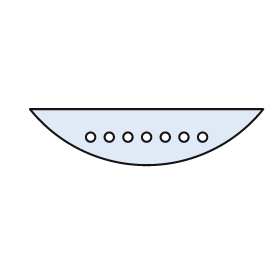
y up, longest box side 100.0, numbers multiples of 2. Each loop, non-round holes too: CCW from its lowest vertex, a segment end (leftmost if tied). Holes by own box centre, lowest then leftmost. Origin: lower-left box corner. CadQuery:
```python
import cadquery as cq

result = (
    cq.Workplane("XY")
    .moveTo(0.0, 24.0)
    .threePointArc((50.0, 0.0), (100.0, 24.0))
    .close()
    .moveTo(26.0, 12.0)
    .circle(2.0)
    .moveTo(34.0, 12.0)
    .circle(2.0)
    .moveTo(42.0, 12.0)
    .circle(2.0)
    .moveTo(50.0, 12.0)
    .circle(2.0)
    .moveTo(58.0, 12.0)
    .circle(2.0)
    .moveTo(66.0, 12.0)
    .circle(2.0)
    .moveTo(74.0, 12.0)
    .circle(2.0)
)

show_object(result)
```